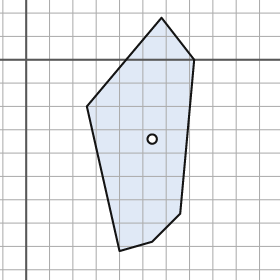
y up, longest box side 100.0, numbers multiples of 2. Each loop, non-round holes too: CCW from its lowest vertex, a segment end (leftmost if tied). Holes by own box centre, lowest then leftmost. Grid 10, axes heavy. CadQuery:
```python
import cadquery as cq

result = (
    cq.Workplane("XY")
    .moveTo(40.0, -82.0)
    .lineTo(54.0, -78.0)
    .lineTo(66.0, -66.0)
    .lineTo(72.0, 0.0)
    .lineTo(58.0, 18.0)
    .lineTo(26.0, -20.0)
    .close()
    .moveTo(54.0, -34.0)
    .circle(2.0)
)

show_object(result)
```